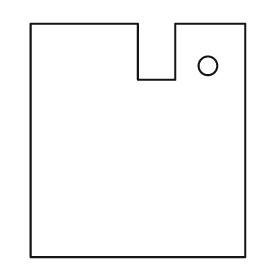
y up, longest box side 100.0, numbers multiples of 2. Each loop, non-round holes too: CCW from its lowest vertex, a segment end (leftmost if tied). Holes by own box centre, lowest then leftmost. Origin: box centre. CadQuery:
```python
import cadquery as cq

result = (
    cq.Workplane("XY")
    .moveTo(-46.0, -50.0)
    .lineTo(46.0, -50.0)
    .lineTo(46.0, 50.0)
    .lineTo(16.0, 50.0)
    .lineTo(16.0, 26.0)
    .lineTo(0.0, 26.0)
    .lineTo(0.0, 50.0)
    .lineTo(-46.0, 50.0)
    .close()
    .moveTo(30.0, 32.0)
    .circle(4.0)
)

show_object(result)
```